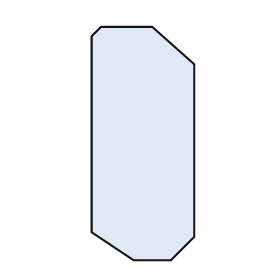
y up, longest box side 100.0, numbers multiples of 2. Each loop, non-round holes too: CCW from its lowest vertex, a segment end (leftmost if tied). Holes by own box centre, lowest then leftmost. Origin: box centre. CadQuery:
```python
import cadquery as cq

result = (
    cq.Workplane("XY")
    .moveTo(-4.0, -50.0)
    .lineTo(12.0, -50.0)
    .lineTo(22.0, -40.0)
    .lineTo(22.0, 34.0)
    .lineTo(4.0, 50.0)
    .lineTo(-18.0, 50.0)
    .lineTo(-22.0, 46.0)
    .lineTo(-22.0, -38.0)
    .close()
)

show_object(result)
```